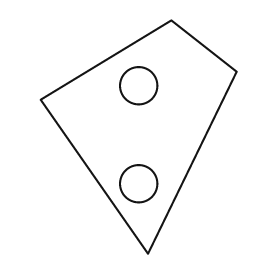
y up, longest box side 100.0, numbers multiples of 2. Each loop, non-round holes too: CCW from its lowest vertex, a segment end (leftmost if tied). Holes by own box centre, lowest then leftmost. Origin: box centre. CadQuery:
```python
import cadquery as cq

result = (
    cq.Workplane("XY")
    .moveTo(4.0, -50.0)
    .lineTo(42.0, 28.0)
    .lineTo(14.0, 50.0)
    .lineTo(-42.0, 16.0)
    .close()
    .moveTo(0.0, -20.0)
    .circle(8.0)
    .moveTo(0.0, 22.0)
    .circle(8.0)
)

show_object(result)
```